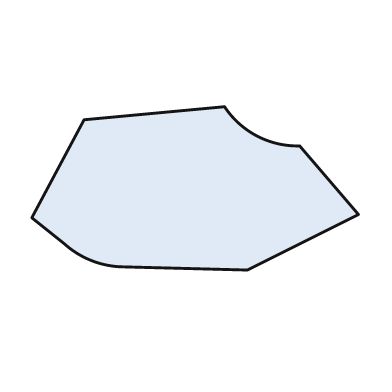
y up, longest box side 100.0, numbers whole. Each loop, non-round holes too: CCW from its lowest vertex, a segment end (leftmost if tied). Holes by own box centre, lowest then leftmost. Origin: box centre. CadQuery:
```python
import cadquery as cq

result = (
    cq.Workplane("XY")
    .moveTo(16.0, -25.0)
    .lineTo(50.0, -8.0)
    .lineTo(32.0, 13.0)
    .threePointArc((19.0, 16.0), (9.0, 25.0))
    .lineTo(-34.0, 21.0)
    .lineTo(-50.0, -9.0)
    .lineTo(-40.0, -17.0)
    .threePointArc((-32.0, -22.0), (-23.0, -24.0))
    .close()
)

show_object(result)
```